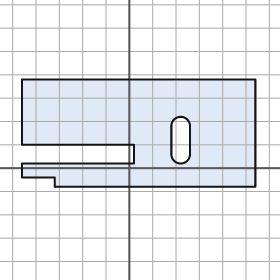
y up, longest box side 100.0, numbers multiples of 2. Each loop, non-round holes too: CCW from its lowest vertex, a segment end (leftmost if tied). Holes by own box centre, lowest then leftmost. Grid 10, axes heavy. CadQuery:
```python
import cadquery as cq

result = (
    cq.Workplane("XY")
    .moveTo(-32.0, -8.0)
    .lineTo(54.0, -8.0)
    .lineTo(54.0, 38.0)
    .lineTo(-46.0, 38.0)
    .lineTo(-46.0, 10.0)
    .lineTo(2.0, 10.0)
    .lineTo(2.0, 2.0)
    .lineTo(-46.0, 2.0)
    .lineTo(-46.0, -4.0)
    .lineTo(-32.0, -4.0)
    .close()
    .moveTo(18.0, 6.0)
    .threePointArc((22.0, 2.0), (26.0, 6.0))
    .lineTo(26.0, 18.0)
    .threePointArc((22.0, 22.0), (18.0, 18.0))
    .close()
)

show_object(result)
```